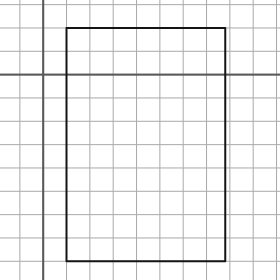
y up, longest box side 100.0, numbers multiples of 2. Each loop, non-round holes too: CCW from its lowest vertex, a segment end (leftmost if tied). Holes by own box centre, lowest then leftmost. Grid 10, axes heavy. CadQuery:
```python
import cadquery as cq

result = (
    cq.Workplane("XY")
    .moveTo(10.0, -80.0)
    .lineTo(78.0, -80.0)
    .lineTo(78.0, 20.0)
    .lineTo(10.0, 20.0)
    .close()
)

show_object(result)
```